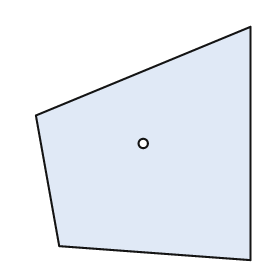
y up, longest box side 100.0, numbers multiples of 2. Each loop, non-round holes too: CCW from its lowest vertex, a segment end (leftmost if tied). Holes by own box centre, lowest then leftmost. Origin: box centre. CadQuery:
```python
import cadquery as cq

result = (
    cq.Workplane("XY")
    .moveTo(46.0, -50.0)
    .lineTo(46.0, 50.0)
    .lineTo(-46.0, 12.0)
    .lineTo(-36.0, -44.0)
    .close()
    .moveTo(0.0, 0.0)
    .circle(2.0)
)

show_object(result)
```